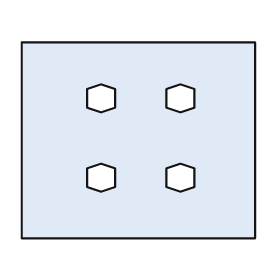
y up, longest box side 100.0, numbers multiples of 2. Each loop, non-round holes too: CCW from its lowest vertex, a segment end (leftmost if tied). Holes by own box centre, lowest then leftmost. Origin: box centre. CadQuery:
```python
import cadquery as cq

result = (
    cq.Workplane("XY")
    .moveTo(-50.0, -42.0)
    .lineTo(50.0, -42.0)
    .lineTo(50.0, 42.0)
    .lineTo(-50.0, 42.0)
    .close()
    .moveTo(-16.0, -22.0)
    .lineTo(-10.0, -20.0)
    .lineTo(-10.0, -12.0)
    .lineTo(-16.0, -10.0)
    .lineTo(-22.0, -12.0)
    .lineTo(-22.0, -20.0)
    .close()
    .moveTo(18.0, -22.0)
    .lineTo(24.0, -20.0)
    .lineTo(24.0, -12.0)
    .lineTo(18.0, -10.0)
    .lineTo(12.0, -12.0)
    .lineTo(12.0, -20.0)
    .close()
    .moveTo(-16.0, 12.0)
    .lineTo(-10.0, 14.0)
    .lineTo(-10.0, 22.0)
    .lineTo(-16.0, 24.0)
    .lineTo(-22.0, 22.0)
    .lineTo(-22.0, 14.0)
    .close()
    .moveTo(18.0, 12.0)
    .lineTo(24.0, 14.0)
    .lineTo(24.0, 22.0)
    .lineTo(18.0, 24.0)
    .lineTo(12.0, 22.0)
    .lineTo(12.0, 14.0)
    .close()
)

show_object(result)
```